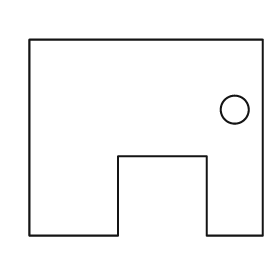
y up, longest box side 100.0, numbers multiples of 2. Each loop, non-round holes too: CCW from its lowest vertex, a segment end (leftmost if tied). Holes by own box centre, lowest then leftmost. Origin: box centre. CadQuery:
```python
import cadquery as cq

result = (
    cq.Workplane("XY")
    .moveTo(-50.0, -42.0)
    .lineTo(-12.0, -42.0)
    .lineTo(-12.0, -8.0)
    .lineTo(26.0, -8.0)
    .lineTo(26.0, -42.0)
    .lineTo(50.0, -42.0)
    .lineTo(50.0, 42.0)
    .lineTo(-50.0, 42.0)
    .close()
    .moveTo(38.0, 12.0)
    .circle(6.0)
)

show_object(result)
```